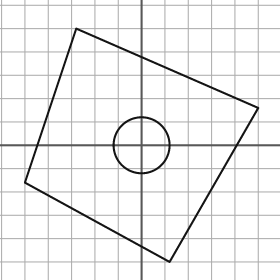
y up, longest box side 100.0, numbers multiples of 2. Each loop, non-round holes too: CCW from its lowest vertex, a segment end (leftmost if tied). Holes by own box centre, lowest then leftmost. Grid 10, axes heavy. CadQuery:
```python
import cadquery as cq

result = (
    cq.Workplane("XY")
    .moveTo(12.0, -50.0)
    .lineTo(50.0, 16.0)
    .lineTo(-28.0, 50.0)
    .lineTo(-50.0, -16.0)
    .close()
    .moveTo(0.0, 0.0)
    .circle(12.0)
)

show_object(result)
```